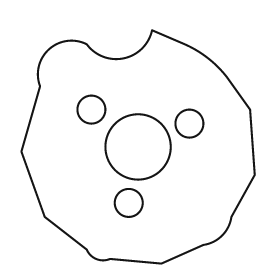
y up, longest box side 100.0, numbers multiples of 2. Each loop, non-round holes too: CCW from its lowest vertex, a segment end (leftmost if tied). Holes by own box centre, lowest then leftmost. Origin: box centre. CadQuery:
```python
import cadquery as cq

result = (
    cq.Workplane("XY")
    .moveTo(10.0, -50.0)
    .lineTo(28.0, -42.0)
    .threePointArc((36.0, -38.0), (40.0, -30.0))
    .lineTo(50.0, -12.0)
    .lineTo(48.0, 16.0)
    .lineTo(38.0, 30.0)
    .threePointArc((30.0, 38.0), (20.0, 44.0))
    .lineTo(6.0, 50.0)
    .threePointArc((-6.0, 38.0), (-22.0, 44.0))
    .threePointArc((-38.0, 42.0), (-42.0, 26.0))
    .lineTo(-50.0, -2.0)
    .lineTo(-40.0, -30.0)
    .lineTo(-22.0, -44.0)
    .threePointArc((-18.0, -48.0), (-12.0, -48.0))
    .close()
    .moveTo(-4.0, -24.0)
    .circle(6.0)
    .moveTo(0.0, 0.0)
    .circle(14.0)
    .moveTo(22.0, 10.0)
    .circle(6.0)
    .moveTo(-20.0, 16.0)
    .circle(6.0)
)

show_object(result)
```